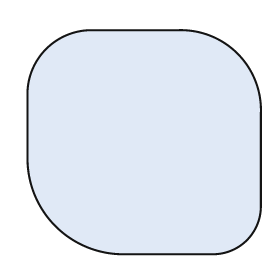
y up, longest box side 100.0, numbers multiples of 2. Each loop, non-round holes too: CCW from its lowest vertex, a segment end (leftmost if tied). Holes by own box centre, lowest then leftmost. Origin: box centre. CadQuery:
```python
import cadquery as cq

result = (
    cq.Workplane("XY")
    .moveTo(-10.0, -48.0)
    .lineTo(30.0, -48.0)
    .threePointArc((44.0, -42.0), (50.0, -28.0))
    .lineTo(50.0, 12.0)
    .threePointArc((40.0, 38.0), (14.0, 48.0))
    .lineTo(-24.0, 48.0)
    .threePointArc((-42.0, 40.0), (-50.0, 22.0))
    .lineTo(-50.0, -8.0)
    .threePointArc((-38.0, -36.0), (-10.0, -48.0))
    .close()
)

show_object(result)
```